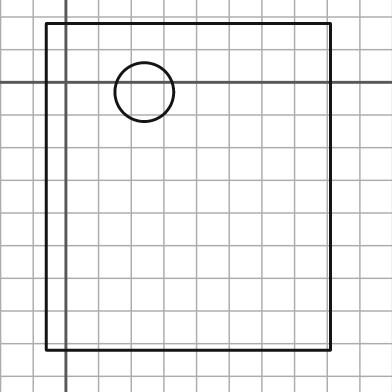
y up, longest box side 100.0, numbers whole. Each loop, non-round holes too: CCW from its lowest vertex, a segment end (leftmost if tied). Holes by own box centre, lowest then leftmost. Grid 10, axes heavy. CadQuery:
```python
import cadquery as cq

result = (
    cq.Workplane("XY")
    .moveTo(-6.0, -82.0)
    .lineTo(81.0, -82.0)
    .lineTo(81.0, 18.0)
    .lineTo(-6.0, 18.0)
    .close()
    .moveTo(24.0, -3.0)
    .circle(9.0)
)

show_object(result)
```